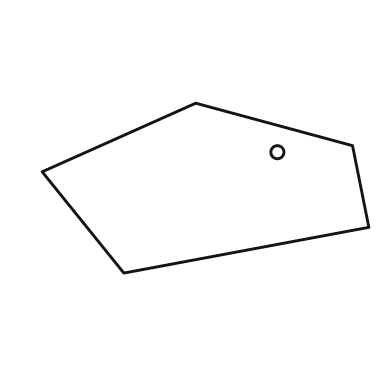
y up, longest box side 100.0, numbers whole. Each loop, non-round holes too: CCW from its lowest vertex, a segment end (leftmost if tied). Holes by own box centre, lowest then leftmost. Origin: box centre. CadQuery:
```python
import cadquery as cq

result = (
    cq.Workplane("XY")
    .moveTo(-25.0, -26.0)
    .lineTo(50.0, -12.0)
    .lineTo(45.0, 13.0)
    .lineTo(-3.0, 26.0)
    .lineTo(-50.0, 5.0)
    .close()
    .moveTo(22.0, 11.0)
    .circle(2.0)
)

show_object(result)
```